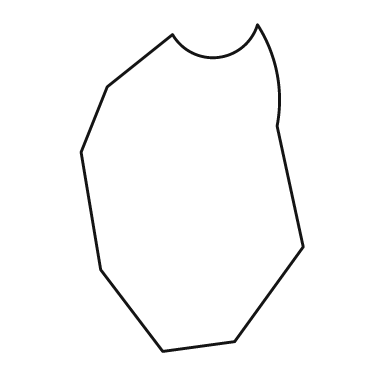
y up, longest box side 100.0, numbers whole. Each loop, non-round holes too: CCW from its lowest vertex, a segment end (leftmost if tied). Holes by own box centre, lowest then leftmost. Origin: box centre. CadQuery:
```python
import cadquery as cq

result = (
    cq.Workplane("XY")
    .moveTo(-9.0, -50.0)
    .lineTo(13.0, -47.0)
    .lineTo(34.0, -18.0)
    .lineTo(26.0, 19.0)
    .threePointArc((26.0, 35.0), (20.0, 50.0))
    .threePointArc((8.0, 40.0), (-6.0, 47.0))
    .lineTo(-26.0, 31.0)
    .lineTo(-34.0, 11.0)
    .lineTo(-28.0, -25.0)
    .close()
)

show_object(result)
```